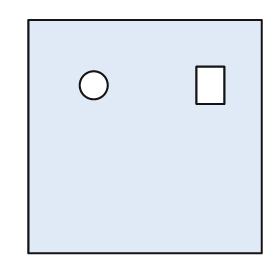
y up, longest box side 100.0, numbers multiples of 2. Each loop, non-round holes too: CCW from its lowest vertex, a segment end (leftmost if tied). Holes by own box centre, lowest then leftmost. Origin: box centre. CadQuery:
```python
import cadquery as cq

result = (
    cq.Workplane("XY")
    .moveTo(-50.0, -50.0)
    .lineTo(50.0, -50.0)
    .lineTo(50.0, 50.0)
    .lineTo(-50.0, 50.0)
    .close()
    .moveTo(-22.0, 22.0)
    .circle(6.0)
    .moveTo(22.0, 14.0)
    .lineTo(34.0, 14.0)
    .lineTo(34.0, 30.0)
    .lineTo(22.0, 30.0)
    .close()
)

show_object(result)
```